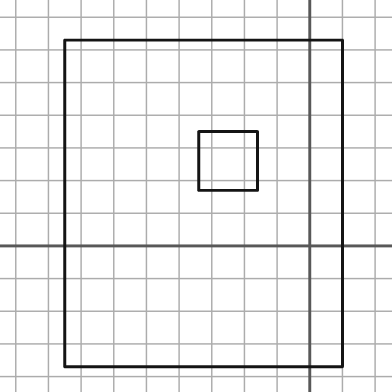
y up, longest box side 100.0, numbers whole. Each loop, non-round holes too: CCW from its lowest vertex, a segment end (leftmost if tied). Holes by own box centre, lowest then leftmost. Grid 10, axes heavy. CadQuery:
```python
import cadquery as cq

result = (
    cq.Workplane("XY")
    .moveTo(-75.0, -37.0)
    .lineTo(10.0, -37.0)
    .lineTo(10.0, 63.0)
    .lineTo(-75.0, 63.0)
    .close()
    .moveTo(-34.0, 17.0)
    .lineTo(-16.0, 17.0)
    .lineTo(-16.0, 35.0)
    .lineTo(-34.0, 35.0)
    .close()
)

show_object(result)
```